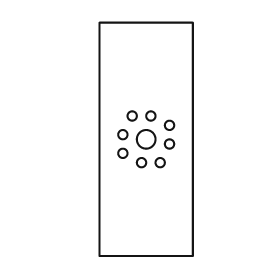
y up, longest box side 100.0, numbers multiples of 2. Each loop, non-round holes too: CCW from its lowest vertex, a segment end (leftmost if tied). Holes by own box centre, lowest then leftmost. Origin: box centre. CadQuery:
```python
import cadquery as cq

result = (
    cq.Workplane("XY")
    .moveTo(-20.0, -50.0)
    .lineTo(20.0, -50.0)
    .lineTo(20.0, 50.0)
    .lineTo(-20.0, 50.0)
    .close()
    .moveTo(-2.0, -10.0)
    .circle(2.0)
    .moveTo(6.0, -10.0)
    .circle(2.0)
    .moveTo(-10.0, -6.0)
    .circle(2.0)
    .moveTo(10.0, -2.0)
    .circle(2.0)
    .moveTo(0.0, 0.0)
    .circle(4.0)
    .moveTo(-10.0, 2.0)
    .circle(2.0)
    .moveTo(10.0, 6.0)
    .circle(2.0)
    .moveTo(-6.0, 10.0)
    .circle(2.0)
    .moveTo(2.0, 10.0)
    .circle(2.0)
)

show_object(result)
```